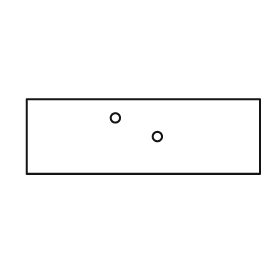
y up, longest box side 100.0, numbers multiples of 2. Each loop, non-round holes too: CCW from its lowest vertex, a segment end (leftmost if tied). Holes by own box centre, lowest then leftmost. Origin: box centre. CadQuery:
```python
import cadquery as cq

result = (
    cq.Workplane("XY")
    .moveTo(-50.0, -16.0)
    .lineTo(50.0, -16.0)
    .lineTo(50.0, 16.0)
    .lineTo(-50.0, 16.0)
    .close()
    .moveTo(6.0, 0.0)
    .circle(2.0)
    .moveTo(-12.0, 8.0)
    .circle(2.0)
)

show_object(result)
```